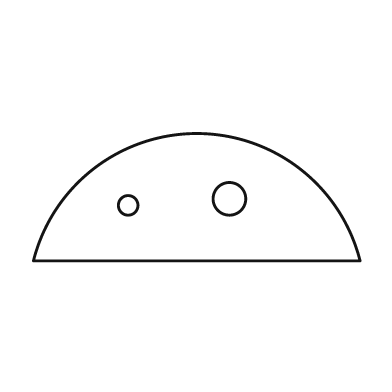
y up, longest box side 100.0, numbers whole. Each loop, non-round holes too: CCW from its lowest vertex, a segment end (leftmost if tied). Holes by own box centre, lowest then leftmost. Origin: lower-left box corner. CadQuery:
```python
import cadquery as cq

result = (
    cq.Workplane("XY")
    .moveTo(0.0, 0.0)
    .lineTo(100.0, 0.0)
    .threePointArc((50.0, 39.0), (0.0, 0.0))
    .close()
    .moveTo(29.0, 17.0)
    .circle(3.0)
    .moveTo(60.0, 19.0)
    .circle(5.0)
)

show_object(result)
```